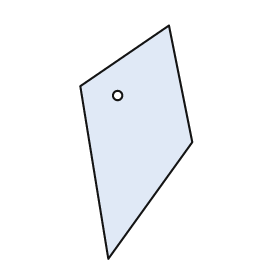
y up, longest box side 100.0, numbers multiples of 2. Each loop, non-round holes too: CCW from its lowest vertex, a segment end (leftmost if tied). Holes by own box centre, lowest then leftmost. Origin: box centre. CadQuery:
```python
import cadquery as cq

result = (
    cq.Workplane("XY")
    .moveTo(-12.0, -50.0)
    .lineTo(24.0, 0.0)
    .lineTo(14.0, 50.0)
    .lineTo(-24.0, 24.0)
    .close()
    .moveTo(-8.0, 20.0)
    .circle(2.0)
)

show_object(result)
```